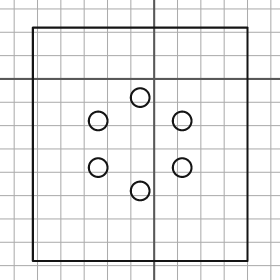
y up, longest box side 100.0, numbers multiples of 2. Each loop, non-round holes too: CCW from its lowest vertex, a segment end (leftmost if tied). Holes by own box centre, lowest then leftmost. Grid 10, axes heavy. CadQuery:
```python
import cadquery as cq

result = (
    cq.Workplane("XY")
    .moveTo(-52.0, -78.0)
    .lineTo(40.0, -78.0)
    .lineTo(40.0, 22.0)
    .lineTo(-52.0, 22.0)
    .close()
    .moveTo(-6.0, -48.0)
    .circle(4.0)
    .moveTo(-24.0, -38.0)
    .circle(4.0)
    .moveTo(12.0, -38.0)
    .circle(4.0)
    .moveTo(-24.0, -18.0)
    .circle(4.0)
    .moveTo(12.0, -18.0)
    .circle(4.0)
    .moveTo(-6.0, -8.0)
    .circle(4.0)
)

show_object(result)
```